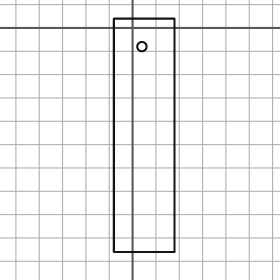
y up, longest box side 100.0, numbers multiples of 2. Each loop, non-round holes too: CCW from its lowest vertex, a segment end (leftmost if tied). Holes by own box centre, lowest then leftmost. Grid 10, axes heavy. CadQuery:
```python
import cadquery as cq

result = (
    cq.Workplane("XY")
    .moveTo(-8.0, -96.0)
    .lineTo(18.0, -96.0)
    .lineTo(18.0, 4.0)
    .lineTo(-8.0, 4.0)
    .close()
    .moveTo(4.0, -8.0)
    .circle(2.0)
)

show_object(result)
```